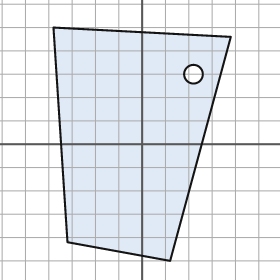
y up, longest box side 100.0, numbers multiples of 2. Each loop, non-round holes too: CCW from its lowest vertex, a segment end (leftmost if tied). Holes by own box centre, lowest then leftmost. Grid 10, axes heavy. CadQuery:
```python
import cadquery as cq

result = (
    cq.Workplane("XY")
    .moveTo(12.0, -50.0)
    .lineTo(38.0, 46.0)
    .lineTo(-38.0, 50.0)
    .lineTo(-32.0, -42.0)
    .close()
    .moveTo(22.0, 30.0)
    .circle(4.0)
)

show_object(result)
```